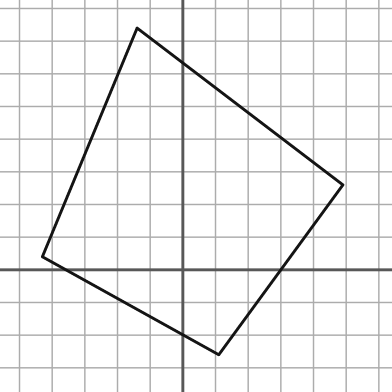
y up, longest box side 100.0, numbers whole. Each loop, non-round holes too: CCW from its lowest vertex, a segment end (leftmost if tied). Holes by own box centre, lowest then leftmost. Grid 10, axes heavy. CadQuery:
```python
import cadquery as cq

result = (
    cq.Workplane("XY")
    .moveTo(11.0, -26.0)
    .lineTo(49.0, 26.0)
    .lineTo(-14.0, 74.0)
    .lineTo(-43.0, 4.0)
    .close()
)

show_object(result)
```